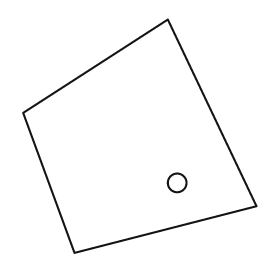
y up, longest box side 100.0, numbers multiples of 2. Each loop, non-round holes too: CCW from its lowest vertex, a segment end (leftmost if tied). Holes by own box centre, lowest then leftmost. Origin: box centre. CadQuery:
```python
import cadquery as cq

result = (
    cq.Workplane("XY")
    .moveTo(-28.0, -50.0)
    .lineTo(50.0, -30.0)
    .lineTo(12.0, 50.0)
    .lineTo(-50.0, 10.0)
    .close()
    .moveTo(16.0, -20.0)
    .circle(4.0)
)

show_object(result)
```